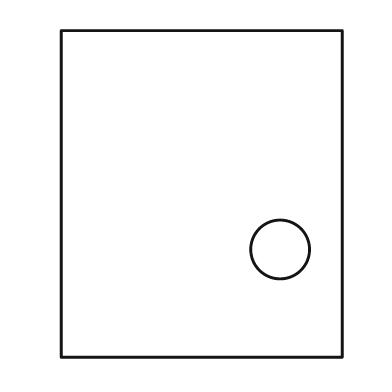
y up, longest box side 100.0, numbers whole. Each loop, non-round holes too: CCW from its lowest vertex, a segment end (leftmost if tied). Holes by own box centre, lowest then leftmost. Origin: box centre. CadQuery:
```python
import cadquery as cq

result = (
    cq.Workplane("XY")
    .moveTo(-43.0, -50.0)
    .lineTo(43.0, -50.0)
    .lineTo(43.0, 50.0)
    .lineTo(-43.0, 50.0)
    .close()
    .moveTo(24.0, -17.0)
    .circle(9.0)
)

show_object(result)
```